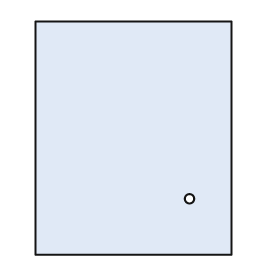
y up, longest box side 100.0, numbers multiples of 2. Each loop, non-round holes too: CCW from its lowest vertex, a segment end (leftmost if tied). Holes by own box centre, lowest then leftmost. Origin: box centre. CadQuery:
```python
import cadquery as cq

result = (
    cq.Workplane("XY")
    .moveTo(-42.0, -50.0)
    .lineTo(42.0, -50.0)
    .lineTo(42.0, 50.0)
    .lineTo(-42.0, 50.0)
    .close()
    .moveTo(24.0, -26.0)
    .circle(2.0)
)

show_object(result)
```